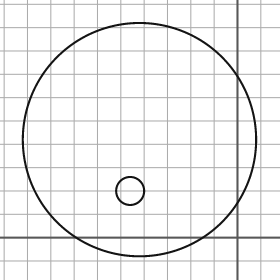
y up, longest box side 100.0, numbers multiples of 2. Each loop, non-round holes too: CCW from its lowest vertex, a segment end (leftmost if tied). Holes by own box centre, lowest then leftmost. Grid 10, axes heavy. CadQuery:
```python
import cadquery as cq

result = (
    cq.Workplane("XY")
    .moveTo(-42.0, 42.0)
    .circle(50.0)
    .moveTo(-46.0, 20.0)
    .circle(6.0)
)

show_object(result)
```